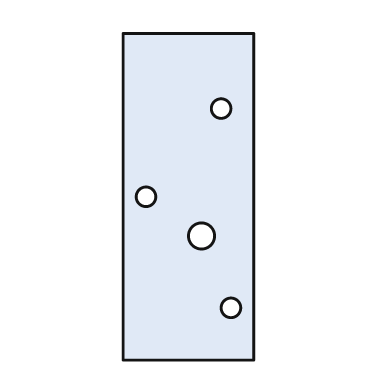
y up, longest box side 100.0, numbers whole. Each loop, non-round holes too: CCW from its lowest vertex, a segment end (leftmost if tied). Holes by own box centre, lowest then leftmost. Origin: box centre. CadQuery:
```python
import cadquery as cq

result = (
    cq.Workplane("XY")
    .moveTo(-20.0, -50.0)
    .lineTo(20.0, -50.0)
    .lineTo(20.0, 50.0)
    .lineTo(-20.0, 50.0)
    .close()
    .moveTo(13.0, -34.0)
    .circle(3.0)
    .moveTo(4.0, -12.0)
    .circle(4.0)
    .moveTo(-13.0, 0.0)
    .circle(3.0)
    .moveTo(10.0, 27.0)
    .circle(3.0)
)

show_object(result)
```